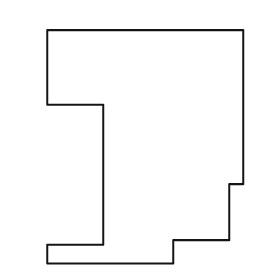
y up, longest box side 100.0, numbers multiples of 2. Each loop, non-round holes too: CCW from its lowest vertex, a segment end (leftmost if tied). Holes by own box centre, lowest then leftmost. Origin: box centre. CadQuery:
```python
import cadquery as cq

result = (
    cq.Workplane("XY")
    .moveTo(-42.0, -50.0)
    .lineTo(12.0, -50.0)
    .lineTo(12.0, -40.0)
    .lineTo(36.0, -40.0)
    .lineTo(36.0, -16.0)
    .lineTo(42.0, -16.0)
    .lineTo(42.0, 50.0)
    .lineTo(-42.0, 50.0)
    .lineTo(-42.0, 18.0)
    .lineTo(-18.0, 18.0)
    .lineTo(-18.0, -42.0)
    .lineTo(-42.0, -42.0)
    .close()
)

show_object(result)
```